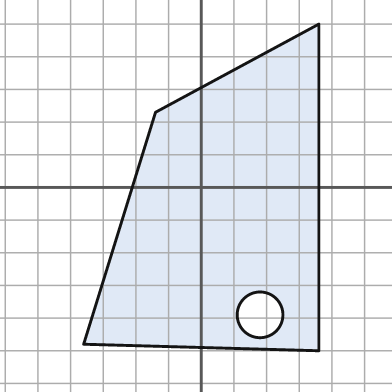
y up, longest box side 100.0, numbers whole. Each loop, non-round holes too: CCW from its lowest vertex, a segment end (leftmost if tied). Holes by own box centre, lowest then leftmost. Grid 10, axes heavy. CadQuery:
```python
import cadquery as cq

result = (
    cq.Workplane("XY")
    .moveTo(36.0, -50.0)
    .lineTo(36.0, 50.0)
    .lineTo(-14.0, 23.0)
    .lineTo(-36.0, -48.0)
    .close()
    .moveTo(18.0, -39.0)
    .circle(7.0)
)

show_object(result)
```